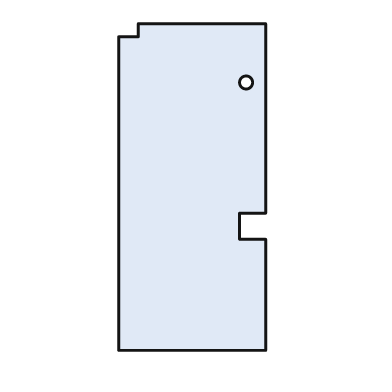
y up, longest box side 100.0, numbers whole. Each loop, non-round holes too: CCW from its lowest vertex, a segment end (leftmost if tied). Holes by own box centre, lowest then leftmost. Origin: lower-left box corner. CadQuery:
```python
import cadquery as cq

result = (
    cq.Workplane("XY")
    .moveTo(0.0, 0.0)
    .lineTo(45.0, 0.0)
    .lineTo(45.0, 34.0)
    .lineTo(37.0, 34.0)
    .lineTo(37.0, 42.0)
    .lineTo(45.0, 42.0)
    .lineTo(45.0, 100.0)
    .lineTo(6.0, 100.0)
    .lineTo(6.0, 96.0)
    .lineTo(0.0, 96.0)
    .close()
    .moveTo(39.0, 82.0)
    .circle(2.0)
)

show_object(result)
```